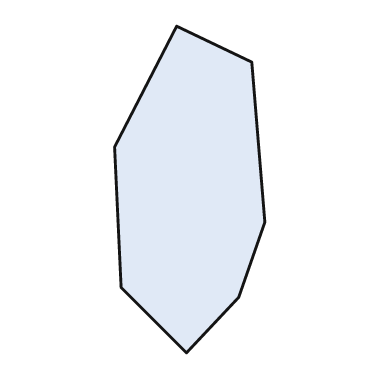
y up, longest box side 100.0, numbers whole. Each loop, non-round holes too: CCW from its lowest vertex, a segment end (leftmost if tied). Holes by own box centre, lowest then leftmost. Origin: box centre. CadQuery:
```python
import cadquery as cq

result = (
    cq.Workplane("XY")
    .moveTo(-1.0, -50.0)
    .lineTo(15.0, -33.0)
    .lineTo(23.0, -10.0)
    .lineTo(19.0, 39.0)
    .lineTo(-4.0, 50.0)
    .lineTo(-23.0, 13.0)
    .lineTo(-21.0, -30.0)
    .close()
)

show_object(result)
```